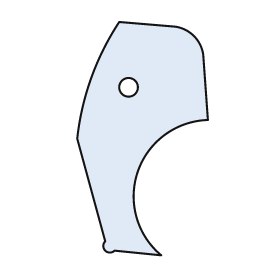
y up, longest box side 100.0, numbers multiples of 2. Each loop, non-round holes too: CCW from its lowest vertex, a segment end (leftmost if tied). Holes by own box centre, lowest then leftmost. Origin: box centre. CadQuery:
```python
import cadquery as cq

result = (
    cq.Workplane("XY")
    .moveTo(8.0, -50.0)
    .threePointArc((-2.0, -14.0), (28.0, 8.0))
    .lineTo(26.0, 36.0)
    .threePointArc((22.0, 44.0), (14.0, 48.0))
    .lineTo(-10.0, 50.0)
    .threePointArc((-22.0, 26.0), (-28.0, 0.0))
    .lineTo(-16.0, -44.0)
    .threePointArc((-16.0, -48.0), (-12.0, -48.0))
    .close()
    .moveTo(-6.0, 22.0)
    .circle(4.0)
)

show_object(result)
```